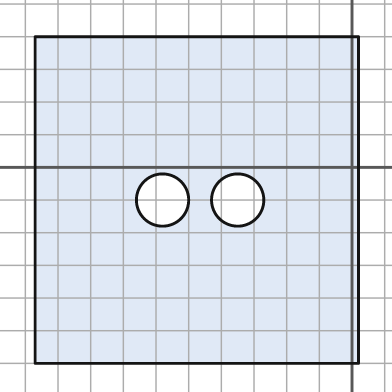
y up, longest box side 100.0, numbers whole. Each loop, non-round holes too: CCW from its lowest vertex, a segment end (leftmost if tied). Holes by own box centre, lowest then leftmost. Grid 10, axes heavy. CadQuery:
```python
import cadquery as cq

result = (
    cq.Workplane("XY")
    .moveTo(-97.0, -60.0)
    .lineTo(2.0, -60.0)
    .lineTo(2.0, 40.0)
    .lineTo(-97.0, 40.0)
    .close()
    .moveTo(-58.0, -10.0)
    .circle(8.0)
    .moveTo(-35.0, -10.0)
    .circle(8.0)
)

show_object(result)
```